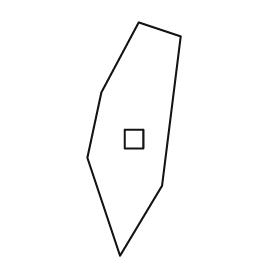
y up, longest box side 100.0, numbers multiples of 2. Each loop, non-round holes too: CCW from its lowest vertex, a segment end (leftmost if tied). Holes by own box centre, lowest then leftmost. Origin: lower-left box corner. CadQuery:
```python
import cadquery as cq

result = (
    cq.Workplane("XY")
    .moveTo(14.0, 0.0)
    .lineTo(32.0, 30.0)
    .lineTo(40.0, 94.0)
    .lineTo(22.0, 100.0)
    .lineTo(6.0, 70.0)
    .lineTo(0.0, 42.0)
    .close()
    .moveTo(16.0, 46.0)
    .lineTo(24.0, 46.0)
    .lineTo(24.0, 54.0)
    .lineTo(16.0, 54.0)
    .close()
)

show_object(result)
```